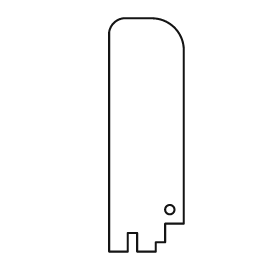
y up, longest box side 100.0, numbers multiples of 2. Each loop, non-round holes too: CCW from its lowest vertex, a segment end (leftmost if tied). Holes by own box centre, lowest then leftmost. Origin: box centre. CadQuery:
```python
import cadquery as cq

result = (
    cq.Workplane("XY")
    .moveTo(-16.0, -50.0)
    .lineTo(-8.0, -50.0)
    .lineTo(-8.0, -42.0)
    .lineTo(-4.0, -42.0)
    .lineTo(-4.0, -50.0)
    .lineTo(4.0, -50.0)
    .lineTo(4.0, -46.0)
    .lineTo(8.0, -46.0)
    .lineTo(8.0, -38.0)
    .lineTo(16.0, -38.0)
    .lineTo(16.0, 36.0)
    .threePointArc((12.0, 46.0), (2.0, 50.0))
    .lineTo(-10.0, 50.0)
    .threePointArc((-14.0, 48.0), (-16.0, 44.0))
    .close()
    .moveTo(10.0, -32.0)
    .circle(2.0)
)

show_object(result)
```